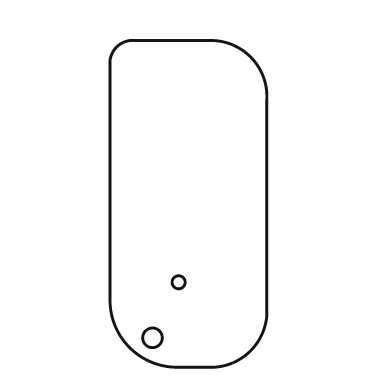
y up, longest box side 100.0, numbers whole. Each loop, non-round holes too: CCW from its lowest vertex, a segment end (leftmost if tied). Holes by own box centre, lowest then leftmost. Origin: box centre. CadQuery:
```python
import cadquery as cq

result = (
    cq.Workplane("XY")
    .moveTo(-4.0, -50.0)
    .lineTo(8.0, -50.0)
    .threePointArc((19.0, -45.0), (24.0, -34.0))
    .lineTo(24.0, 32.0)
    .threePointArc((19.0, 45.0), (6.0, 50.0))
    .lineTo(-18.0, 50.0)
    .threePointArc((-22.0, 48.0), (-24.0, 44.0))
    .lineTo(-24.0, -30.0)
    .threePointArc((-18.0, -44.0), (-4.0, -50.0))
    .close()
    .moveTo(-11.0, -41.0)
    .circle(3.0)
    .moveTo(-3.0, -24.0)
    .circle(2.0)
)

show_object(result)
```